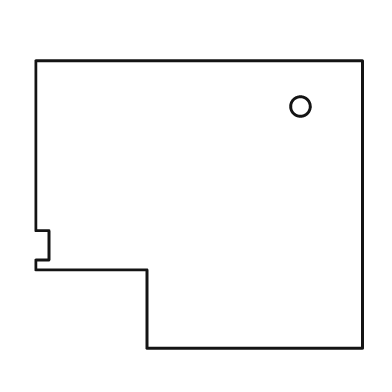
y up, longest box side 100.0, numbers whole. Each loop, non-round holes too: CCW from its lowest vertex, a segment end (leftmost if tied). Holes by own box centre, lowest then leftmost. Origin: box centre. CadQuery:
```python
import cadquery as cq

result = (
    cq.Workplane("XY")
    .moveTo(-16.0, -44.0)
    .lineTo(50.0, -44.0)
    .lineTo(50.0, 44.0)
    .lineTo(-50.0, 44.0)
    .lineTo(-50.0, -8.0)
    .lineTo(-46.0, -8.0)
    .lineTo(-46.0, -17.0)
    .lineTo(-50.0, -17.0)
    .lineTo(-50.0, -20.0)
    .lineTo(-16.0, -20.0)
    .close()
    .moveTo(31.0, 30.0)
    .circle(3.0)
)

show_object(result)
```